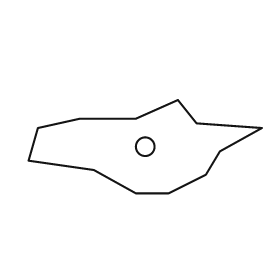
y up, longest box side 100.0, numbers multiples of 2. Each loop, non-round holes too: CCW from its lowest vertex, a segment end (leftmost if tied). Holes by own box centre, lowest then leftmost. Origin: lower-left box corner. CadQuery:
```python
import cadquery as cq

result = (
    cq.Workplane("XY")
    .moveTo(46.0, 0.0)
    .lineTo(60.0, 0.0)
    .lineTo(76.0, 8.0)
    .lineTo(82.0, 18.0)
    .lineTo(100.0, 28.0)
    .lineTo(72.0, 30.0)
    .lineTo(64.0, 40.0)
    .lineTo(46.0, 32.0)
    .lineTo(22.0, 32.0)
    .lineTo(4.0, 28.0)
    .lineTo(0.0, 14.0)
    .lineTo(28.0, 10.0)
    .close()
    .moveTo(50.0, 20.0)
    .circle(4.0)
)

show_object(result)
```